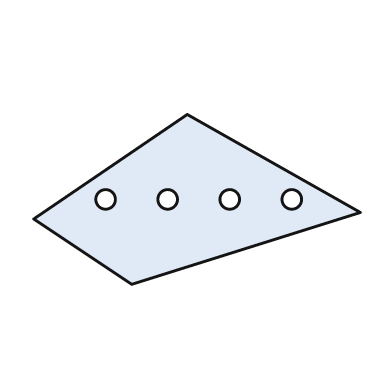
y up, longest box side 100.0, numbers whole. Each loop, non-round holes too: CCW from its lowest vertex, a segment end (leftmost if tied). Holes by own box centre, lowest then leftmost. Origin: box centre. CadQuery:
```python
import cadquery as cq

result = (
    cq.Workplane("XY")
    .moveTo(-20.0, -26.0)
    .lineTo(50.0, -4.0)
    .lineTo(-3.0, 26.0)
    .lineTo(-50.0, -6.0)
    .close()
    .moveTo(-28.0, 0.0)
    .circle(3.0)
    .moveTo(-9.0, 0.0)
    .circle(3.0)
    .moveTo(10.0, 0.0)
    .circle(3.0)
    .moveTo(29.0, 0.0)
    .circle(3.0)
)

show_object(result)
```